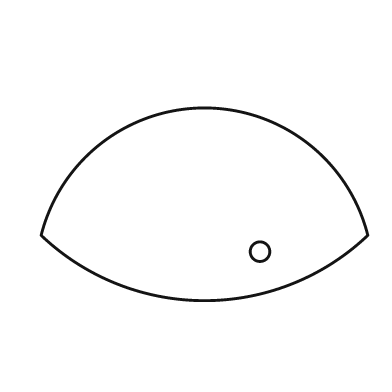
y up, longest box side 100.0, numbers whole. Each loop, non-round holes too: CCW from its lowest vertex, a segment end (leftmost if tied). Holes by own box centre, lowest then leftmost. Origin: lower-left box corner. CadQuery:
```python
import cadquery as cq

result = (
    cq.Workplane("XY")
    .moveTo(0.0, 20.0)
    .threePointArc((50.0, 0.0), (100.0, 20.0))
    .threePointArc((50.0, 59.0), (0.0, 20.0))
    .close()
    .moveTo(67.0, 15.0)
    .circle(3.0)
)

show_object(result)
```